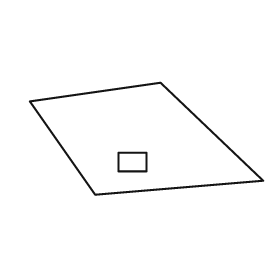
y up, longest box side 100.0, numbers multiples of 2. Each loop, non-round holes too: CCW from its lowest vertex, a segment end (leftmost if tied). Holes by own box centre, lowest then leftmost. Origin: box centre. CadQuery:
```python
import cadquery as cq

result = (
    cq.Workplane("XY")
    .moveTo(-22.0, -24.0)
    .lineTo(50.0, -18.0)
    .lineTo(6.0, 24.0)
    .lineTo(-50.0, 16.0)
    .close()
    .moveTo(-12.0, -14.0)
    .lineTo(0.0, -14.0)
    .lineTo(0.0, -6.0)
    .lineTo(-12.0, -6.0)
    .close()
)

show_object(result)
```